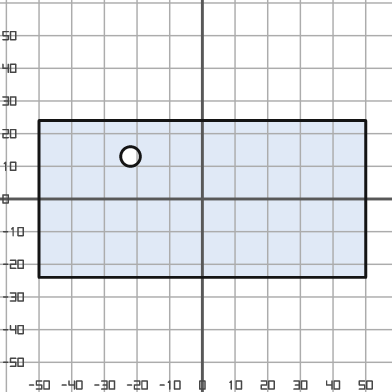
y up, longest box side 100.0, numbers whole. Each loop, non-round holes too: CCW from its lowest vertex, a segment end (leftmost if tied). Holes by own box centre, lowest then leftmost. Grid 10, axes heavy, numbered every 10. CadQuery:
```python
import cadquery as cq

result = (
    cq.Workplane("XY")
    .moveTo(-50.0, -24.0)
    .lineTo(50.0, -24.0)
    .lineTo(50.0, 24.0)
    .lineTo(-50.0, 24.0)
    .close()
    .moveTo(-22.0, 13.0)
    .circle(3.0)
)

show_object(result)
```